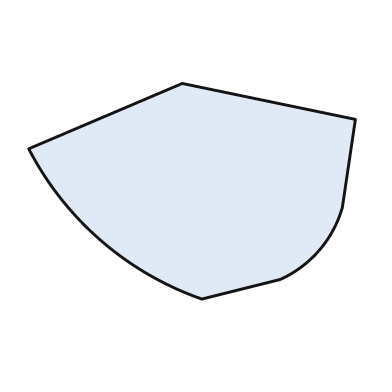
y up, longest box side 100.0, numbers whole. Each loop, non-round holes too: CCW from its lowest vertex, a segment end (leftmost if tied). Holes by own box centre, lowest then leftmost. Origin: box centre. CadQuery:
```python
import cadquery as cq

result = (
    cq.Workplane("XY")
    .moveTo(3.0, -33.0)
    .lineTo(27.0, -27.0)
    .threePointArc((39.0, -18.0), (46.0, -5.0))
    .lineTo(50.0, 22.0)
    .lineTo(-3.0, 33.0)
    .lineTo(-50.0, 13.0)
    .threePointArc((-28.0, -15.0), (3.0, -33.0))
    .close()
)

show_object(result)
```